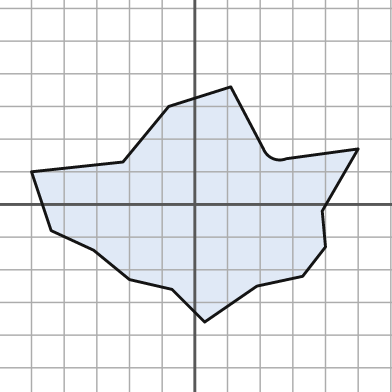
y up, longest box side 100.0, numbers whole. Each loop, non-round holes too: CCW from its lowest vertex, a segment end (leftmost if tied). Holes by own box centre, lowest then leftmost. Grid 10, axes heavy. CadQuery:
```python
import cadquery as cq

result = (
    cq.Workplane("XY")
    .moveTo(3.0, -36.0)
    .lineTo(19.0, -25.0)
    .lineTo(33.0, -22.0)
    .lineTo(40.0, -13.0)
    .lineTo(39.0, -2.0)
    .lineTo(50.0, 17.0)
    .lineTo(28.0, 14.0)
    .threePointArc((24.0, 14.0), (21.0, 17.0))
    .lineTo(11.0, 36.0)
    .lineTo(-8.0, 30.0)
    .lineTo(-22.0, 13.0)
    .lineTo(-50.0, 10.0)
    .lineTo(-44.0, -8.0)
    .lineTo(-31.0, -14.0)
    .lineTo(-20.0, -23.0)
    .lineTo(-7.0, -26.0)
    .close()
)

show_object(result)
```